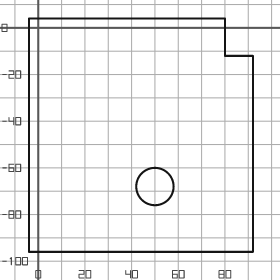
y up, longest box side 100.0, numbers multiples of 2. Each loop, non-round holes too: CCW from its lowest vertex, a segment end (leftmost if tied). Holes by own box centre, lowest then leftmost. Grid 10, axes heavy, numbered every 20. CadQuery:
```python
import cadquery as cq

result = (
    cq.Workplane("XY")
    .moveTo(-4.0, -96.0)
    .lineTo(92.0, -96.0)
    .lineTo(92.0, -12.0)
    .lineTo(80.0, -12.0)
    .lineTo(80.0, 4.0)
    .lineTo(-4.0, 4.0)
    .close()
    .moveTo(50.0, -68.0)
    .circle(8.0)
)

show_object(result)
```